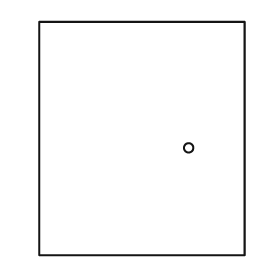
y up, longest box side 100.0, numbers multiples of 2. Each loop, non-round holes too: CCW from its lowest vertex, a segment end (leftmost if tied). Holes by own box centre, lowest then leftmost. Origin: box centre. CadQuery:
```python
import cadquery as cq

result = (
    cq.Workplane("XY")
    .moveTo(-44.0, -50.0)
    .lineTo(44.0, -50.0)
    .lineTo(44.0, 50.0)
    .lineTo(-44.0, 50.0)
    .close()
    .moveTo(20.0, -4.0)
    .circle(2.0)
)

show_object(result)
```